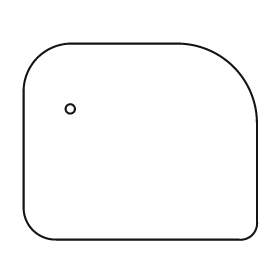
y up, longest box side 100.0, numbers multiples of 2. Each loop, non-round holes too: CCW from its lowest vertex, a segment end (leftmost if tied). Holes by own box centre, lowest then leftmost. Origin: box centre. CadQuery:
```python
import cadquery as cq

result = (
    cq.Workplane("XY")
    .moveTo(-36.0, -42.0)
    .lineTo(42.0, -42.0)
    .threePointArc((48.0, -40.0), (50.0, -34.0))
    .lineTo(50.0, 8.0)
    .threePointArc((40.0, 32.0), (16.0, 42.0))
    .lineTo(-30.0, 42.0)
    .threePointArc((-44.0, 36.0), (-50.0, 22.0))
    .lineTo(-50.0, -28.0)
    .threePointArc((-46.0, -38.0), (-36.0, -42.0))
    .close()
    .moveTo(-30.0, 14.0)
    .circle(2.0)
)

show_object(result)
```